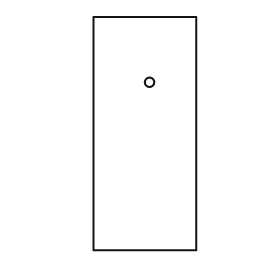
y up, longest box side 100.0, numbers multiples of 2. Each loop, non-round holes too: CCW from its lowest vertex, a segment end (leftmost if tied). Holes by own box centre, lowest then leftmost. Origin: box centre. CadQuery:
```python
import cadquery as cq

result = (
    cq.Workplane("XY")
    .moveTo(-22.0, -50.0)
    .lineTo(22.0, -50.0)
    .lineTo(22.0, 50.0)
    .lineTo(-22.0, 50.0)
    .close()
    .moveTo(2.0, 22.0)
    .circle(2.0)
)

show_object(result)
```